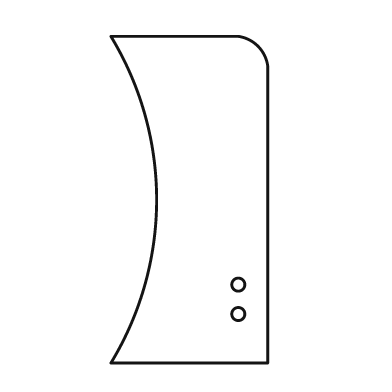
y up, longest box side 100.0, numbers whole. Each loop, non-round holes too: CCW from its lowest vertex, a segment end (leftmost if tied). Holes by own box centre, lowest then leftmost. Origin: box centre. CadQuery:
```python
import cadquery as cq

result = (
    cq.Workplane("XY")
    .moveTo(-24.0, -50.0)
    .lineTo(24.0, -50.0)
    .lineTo(24.0, 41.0)
    .threePointArc((21.0, 47.0), (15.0, 50.0))
    .lineTo(-24.0, 50.0)
    .threePointArc((-10.0, 0.0), (-24.0, -50.0))
    .close()
    .moveTo(15.0, -35.0)
    .circle(2.0)
    .moveTo(15.0, -26.0)
    .circle(2.0)
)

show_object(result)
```